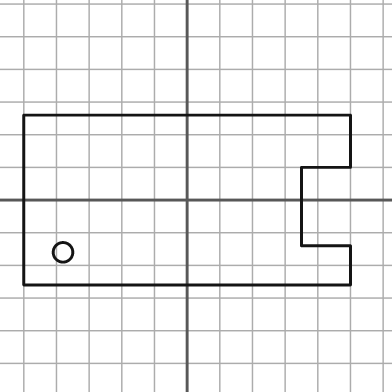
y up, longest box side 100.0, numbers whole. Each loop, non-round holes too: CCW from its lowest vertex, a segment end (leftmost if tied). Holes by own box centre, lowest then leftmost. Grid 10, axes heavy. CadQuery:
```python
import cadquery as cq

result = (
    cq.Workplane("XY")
    .moveTo(-50.0, -26.0)
    .lineTo(50.0, -26.0)
    .lineTo(50.0, -14.0)
    .lineTo(35.0, -14.0)
    .lineTo(35.0, 10.0)
    .lineTo(50.0, 10.0)
    .lineTo(50.0, 26.0)
    .lineTo(-50.0, 26.0)
    .close()
    .moveTo(-38.0, -16.0)
    .circle(3.0)
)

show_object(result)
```